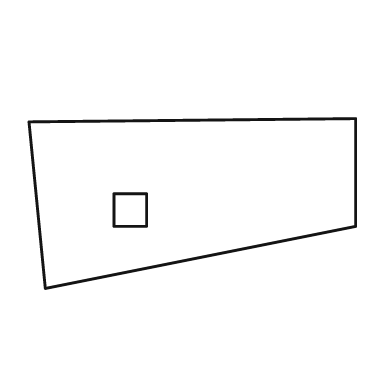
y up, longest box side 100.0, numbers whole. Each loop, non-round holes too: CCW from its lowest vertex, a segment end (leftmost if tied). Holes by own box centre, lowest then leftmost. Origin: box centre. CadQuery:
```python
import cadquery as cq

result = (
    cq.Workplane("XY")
    .moveTo(-45.0, -26.0)
    .lineTo(50.0, -7.0)
    .lineTo(50.0, 26.0)
    .lineTo(-50.0, 25.0)
    .close()
    .moveTo(-24.0, -7.0)
    .lineTo(-14.0, -7.0)
    .lineTo(-14.0, 3.0)
    .lineTo(-24.0, 3.0)
    .close()
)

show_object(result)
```